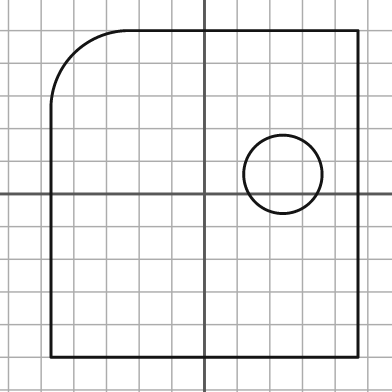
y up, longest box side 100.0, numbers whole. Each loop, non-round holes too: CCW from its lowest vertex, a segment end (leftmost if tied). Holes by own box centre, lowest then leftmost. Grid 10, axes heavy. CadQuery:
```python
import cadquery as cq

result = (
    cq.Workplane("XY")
    .moveTo(-47.0, -50.0)
    .lineTo(47.0, -50.0)
    .lineTo(47.0, 50.0)
    .lineTo(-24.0, 50.0)
    .threePointArc((-40.0, 43.0), (-47.0, 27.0))
    .close()
    .moveTo(24.0, 6.0)
    .circle(12.0)
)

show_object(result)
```